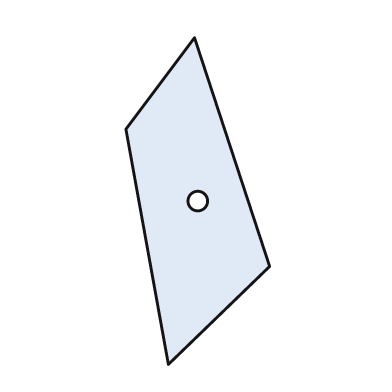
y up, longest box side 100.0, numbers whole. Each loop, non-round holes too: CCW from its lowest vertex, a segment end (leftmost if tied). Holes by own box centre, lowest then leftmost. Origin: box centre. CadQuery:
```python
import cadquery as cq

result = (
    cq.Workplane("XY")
    .moveTo(-9.0, -50.0)
    .lineTo(22.0, -20.0)
    .lineTo(-1.0, 50.0)
    .lineTo(-22.0, 22.0)
    .close()
    .moveTo(0.0, 0.0)
    .circle(3.0)
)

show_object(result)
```